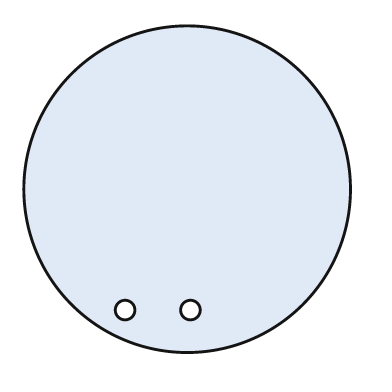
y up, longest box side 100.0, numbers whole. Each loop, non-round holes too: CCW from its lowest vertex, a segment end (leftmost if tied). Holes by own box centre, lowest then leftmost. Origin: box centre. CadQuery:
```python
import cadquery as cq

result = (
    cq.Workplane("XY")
    .moveTo(0.0, 0.0)
    .circle(50.0)
    .moveTo(-19.0, -37.0)
    .circle(3.0)
    .moveTo(1.0, -37.0)
    .circle(3.0)
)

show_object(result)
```